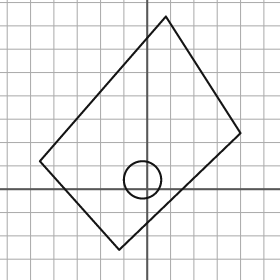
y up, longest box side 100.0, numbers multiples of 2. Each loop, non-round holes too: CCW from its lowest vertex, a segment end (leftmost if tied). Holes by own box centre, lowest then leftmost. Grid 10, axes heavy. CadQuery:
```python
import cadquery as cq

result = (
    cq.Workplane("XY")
    .moveTo(-12.0, -26.0)
    .lineTo(40.0, 24.0)
    .lineTo(8.0, 74.0)
    .lineTo(-46.0, 12.0)
    .close()
    .moveTo(-2.0, 4.0)
    .circle(8.0)
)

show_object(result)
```